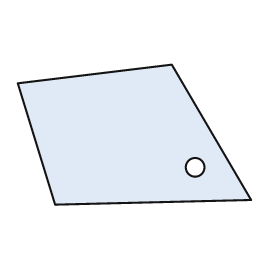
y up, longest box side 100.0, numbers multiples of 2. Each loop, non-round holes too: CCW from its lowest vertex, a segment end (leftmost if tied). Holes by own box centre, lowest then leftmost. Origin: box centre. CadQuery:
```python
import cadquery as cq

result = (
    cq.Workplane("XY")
    .moveTo(-34.0, -30.0)
    .lineTo(50.0, -28.0)
    .lineTo(16.0, 30.0)
    .lineTo(-50.0, 22.0)
    .close()
    .moveTo(26.0, -14.0)
    .circle(4.0)
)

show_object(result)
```